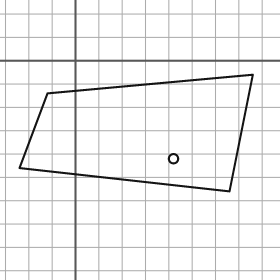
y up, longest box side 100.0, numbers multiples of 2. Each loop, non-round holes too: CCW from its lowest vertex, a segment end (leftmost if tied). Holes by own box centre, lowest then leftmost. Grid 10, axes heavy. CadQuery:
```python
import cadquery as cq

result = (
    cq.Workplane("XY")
    .moveTo(66.0, -56.0)
    .lineTo(76.0, -6.0)
    .lineTo(-12.0, -14.0)
    .lineTo(-24.0, -46.0)
    .close()
    .moveTo(42.0, -42.0)
    .circle(2.0)
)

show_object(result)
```